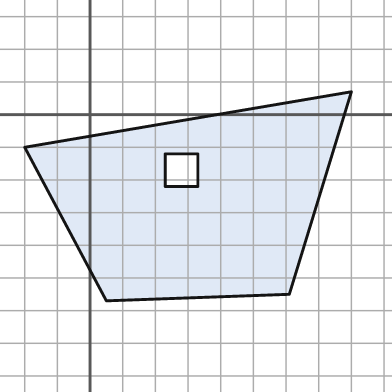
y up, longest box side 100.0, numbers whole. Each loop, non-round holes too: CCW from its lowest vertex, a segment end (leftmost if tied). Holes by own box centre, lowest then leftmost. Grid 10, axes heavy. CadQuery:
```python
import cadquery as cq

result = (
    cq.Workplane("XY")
    .moveTo(5.0, -57.0)
    .lineTo(61.0, -55.0)
    .lineTo(80.0, 7.0)
    .lineTo(-20.0, -10.0)
    .close()
    .moveTo(23.0, -22.0)
    .lineTo(33.0, -22.0)
    .lineTo(33.0, -12.0)
    .lineTo(23.0, -12.0)
    .close()
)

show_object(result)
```